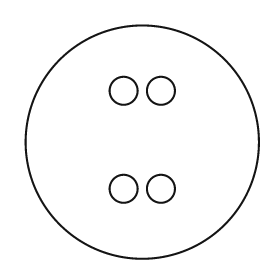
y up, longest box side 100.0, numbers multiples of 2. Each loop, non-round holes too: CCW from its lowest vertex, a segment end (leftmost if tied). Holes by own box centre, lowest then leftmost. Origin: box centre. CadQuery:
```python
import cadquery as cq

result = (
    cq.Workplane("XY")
    .moveTo(0.0, 0.0)
    .circle(50.0)
    .moveTo(-8.0, -20.0)
    .circle(6.0)
    .moveTo(8.0, -20.0)
    .circle(6.0)
    .moveTo(-8.0, 22.0)
    .circle(6.0)
    .moveTo(8.0, 22.0)
    .circle(6.0)
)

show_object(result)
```